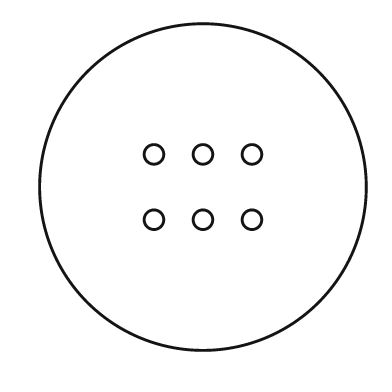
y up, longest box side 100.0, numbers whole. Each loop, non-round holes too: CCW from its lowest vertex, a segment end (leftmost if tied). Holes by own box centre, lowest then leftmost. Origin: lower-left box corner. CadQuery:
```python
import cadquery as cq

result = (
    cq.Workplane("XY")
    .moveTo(50.0, 50.0)
    .circle(50.0)
    .moveTo(35.0, 40.0)
    .circle(3.0)
    .moveTo(50.0, 40.0)
    .circle(3.0)
    .moveTo(65.0, 40.0)
    .circle(3.0)
    .moveTo(35.0, 60.0)
    .circle(3.0)
    .moveTo(50.0, 60.0)
    .circle(3.0)
    .moveTo(65.0, 60.0)
    .circle(3.0)
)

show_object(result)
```